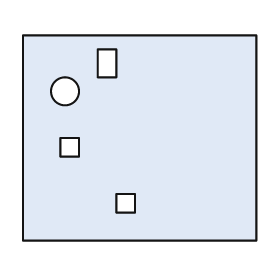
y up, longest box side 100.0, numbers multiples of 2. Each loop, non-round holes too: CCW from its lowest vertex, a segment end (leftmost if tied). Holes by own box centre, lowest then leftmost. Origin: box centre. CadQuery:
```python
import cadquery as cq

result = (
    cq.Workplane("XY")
    .moveTo(-50.0, -44.0)
    .lineTo(50.0, -44.0)
    .lineTo(50.0, 44.0)
    .lineTo(-50.0, 44.0)
    .close()
    .moveTo(-10.0, -32.0)
    .lineTo(-2.0, -32.0)
    .lineTo(-2.0, -24.0)
    .lineTo(-10.0, -24.0)
    .close()
    .moveTo(-34.0, -8.0)
    .lineTo(-26.0, -8.0)
    .lineTo(-26.0, 0.0)
    .lineTo(-34.0, 0.0)
    .close()
    .moveTo(-32.0, 20.0)
    .circle(6.0)
    .moveTo(-18.0, 26.0)
    .lineTo(-10.0, 26.0)
    .lineTo(-10.0, 38.0)
    .lineTo(-18.0, 38.0)
    .close()
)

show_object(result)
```